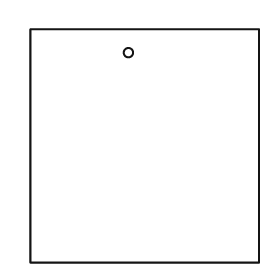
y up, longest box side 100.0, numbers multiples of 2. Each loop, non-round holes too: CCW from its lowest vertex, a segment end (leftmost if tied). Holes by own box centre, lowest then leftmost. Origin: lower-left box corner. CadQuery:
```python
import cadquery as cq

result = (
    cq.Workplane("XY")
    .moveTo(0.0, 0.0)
    .lineTo(98.0, 0.0)
    .lineTo(98.0, 100.0)
    .lineTo(0.0, 100.0)
    .close()
    .moveTo(42.0, 90.0)
    .circle(2.0)
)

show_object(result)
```